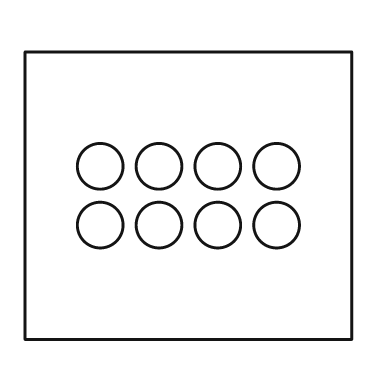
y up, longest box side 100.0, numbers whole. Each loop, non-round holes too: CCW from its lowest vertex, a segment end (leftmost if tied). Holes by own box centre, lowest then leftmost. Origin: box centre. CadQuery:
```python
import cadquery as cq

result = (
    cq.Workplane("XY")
    .moveTo(-50.0, -44.0)
    .lineTo(50.0, -44.0)
    .lineTo(50.0, 44.0)
    .lineTo(-50.0, 44.0)
    .close()
    .moveTo(-27.0, -9.0)
    .circle(7.0)
    .moveTo(-9.0, -9.0)
    .circle(7.0)
    .moveTo(9.0, -9.0)
    .circle(7.0)
    .moveTo(27.0, -9.0)
    .circle(7.0)
    .moveTo(-27.0, 9.0)
    .circle(7.0)
    .moveTo(-9.0, 9.0)
    .circle(7.0)
    .moveTo(9.0, 9.0)
    .circle(7.0)
    .moveTo(27.0, 9.0)
    .circle(7.0)
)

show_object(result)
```